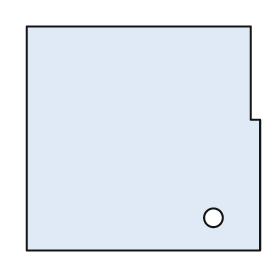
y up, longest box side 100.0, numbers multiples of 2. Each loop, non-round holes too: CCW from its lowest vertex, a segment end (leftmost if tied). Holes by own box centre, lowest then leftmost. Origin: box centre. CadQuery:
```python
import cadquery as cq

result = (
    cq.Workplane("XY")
    .moveTo(-50.0, -48.0)
    .lineTo(50.0, -48.0)
    .lineTo(50.0, 8.0)
    .lineTo(46.0, 8.0)
    .lineTo(46.0, 48.0)
    .lineTo(-50.0, 48.0)
    .close()
    .moveTo(30.0, -34.0)
    .circle(4.0)
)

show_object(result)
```